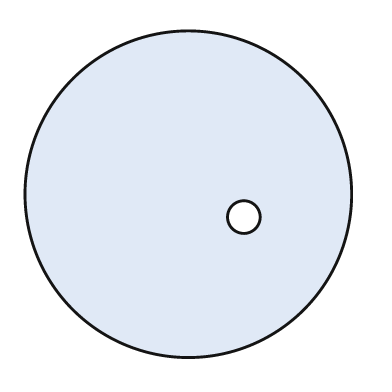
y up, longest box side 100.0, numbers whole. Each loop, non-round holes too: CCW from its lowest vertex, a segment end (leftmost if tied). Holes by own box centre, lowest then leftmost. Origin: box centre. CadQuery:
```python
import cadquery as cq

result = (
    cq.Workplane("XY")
    .moveTo(0.0, 0.0)
    .circle(50.0)
    .moveTo(17.0, -7.0)
    .circle(5.0)
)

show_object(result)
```